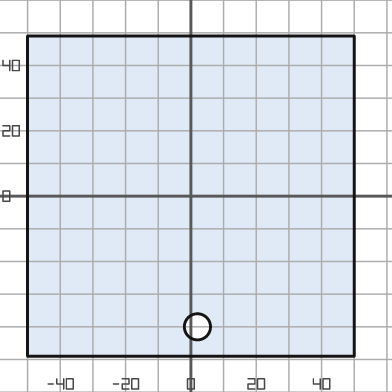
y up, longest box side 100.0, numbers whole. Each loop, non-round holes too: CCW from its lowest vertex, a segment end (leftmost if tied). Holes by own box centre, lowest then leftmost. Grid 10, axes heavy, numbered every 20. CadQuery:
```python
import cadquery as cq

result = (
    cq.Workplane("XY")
    .moveTo(-50.0, -49.0)
    .lineTo(50.0, -49.0)
    .lineTo(50.0, 49.0)
    .lineTo(-50.0, 49.0)
    .close()
    .moveTo(2.0, -40.0)
    .circle(4.0)
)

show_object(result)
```